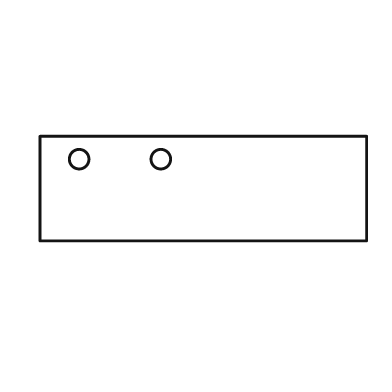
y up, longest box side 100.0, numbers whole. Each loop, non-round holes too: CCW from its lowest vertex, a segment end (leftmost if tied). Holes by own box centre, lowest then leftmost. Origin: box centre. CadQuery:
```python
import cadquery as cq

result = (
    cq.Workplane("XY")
    .moveTo(-50.0, -16.0)
    .lineTo(50.0, -16.0)
    .lineTo(50.0, 16.0)
    .lineTo(-50.0, 16.0)
    .close()
    .moveTo(-38.0, 9.0)
    .circle(3.0)
    .moveTo(-13.0, 9.0)
    .circle(3.0)
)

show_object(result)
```